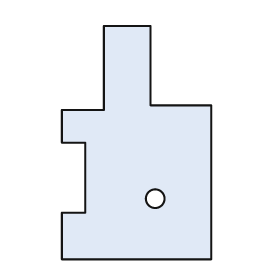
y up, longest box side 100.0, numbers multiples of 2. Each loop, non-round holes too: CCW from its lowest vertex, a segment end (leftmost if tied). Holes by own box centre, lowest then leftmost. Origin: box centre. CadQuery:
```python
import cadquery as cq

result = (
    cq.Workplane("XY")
    .moveTo(-32.0, -50.0)
    .lineTo(32.0, -50.0)
    .lineTo(32.0, 16.0)
    .lineTo(6.0, 16.0)
    .lineTo(6.0, 50.0)
    .lineTo(-14.0, 50.0)
    .lineTo(-14.0, 14.0)
    .lineTo(-32.0, 14.0)
    .lineTo(-32.0, 0.0)
    .lineTo(-22.0, 0.0)
    .lineTo(-22.0, -30.0)
    .lineTo(-32.0, -30.0)
    .close()
    .moveTo(8.0, -24.0)
    .circle(4.0)
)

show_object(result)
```